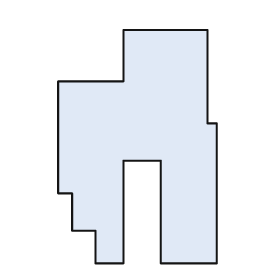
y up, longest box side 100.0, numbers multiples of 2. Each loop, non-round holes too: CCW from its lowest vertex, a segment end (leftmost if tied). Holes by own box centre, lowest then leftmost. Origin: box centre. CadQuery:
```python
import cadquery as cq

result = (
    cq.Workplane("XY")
    .moveTo(-18.0, -50.0)
    .lineTo(-6.0, -50.0)
    .lineTo(-6.0, -6.0)
    .lineTo(10.0, -6.0)
    .lineTo(10.0, -50.0)
    .lineTo(34.0, -50.0)
    .lineTo(34.0, 10.0)
    .lineTo(30.0, 10.0)
    .lineTo(30.0, 50.0)
    .lineTo(-6.0, 50.0)
    .lineTo(-6.0, 28.0)
    .lineTo(-34.0, 28.0)
    .lineTo(-34.0, -20.0)
    .lineTo(-28.0, -20.0)
    .lineTo(-28.0, -36.0)
    .lineTo(-18.0, -36.0)
    .close()
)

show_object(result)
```